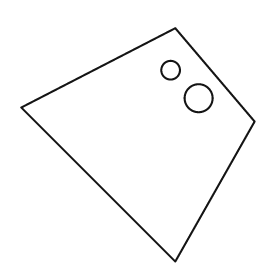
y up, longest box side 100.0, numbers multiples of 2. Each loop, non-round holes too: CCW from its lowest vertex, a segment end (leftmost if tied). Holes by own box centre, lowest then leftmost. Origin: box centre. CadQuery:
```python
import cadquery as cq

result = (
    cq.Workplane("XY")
    .moveTo(16.0, -50.0)
    .lineTo(50.0, 10.0)
    .lineTo(16.0, 50.0)
    .lineTo(-50.0, 16.0)
    .close()
    .moveTo(26.0, 20.0)
    .circle(6.0)
    .moveTo(14.0, 32.0)
    .circle(4.0)
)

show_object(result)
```